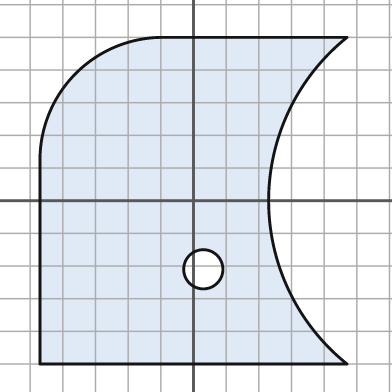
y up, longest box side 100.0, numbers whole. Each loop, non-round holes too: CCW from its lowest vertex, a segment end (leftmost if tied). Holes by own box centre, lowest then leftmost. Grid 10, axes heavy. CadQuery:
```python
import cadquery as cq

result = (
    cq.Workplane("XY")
    .moveTo(-47.0, -50.0)
    .lineTo(47.0, -50.0)
    .threePointArc((23.0, 0.0), (47.0, 50.0))
    .lineTo(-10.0, 50.0)
    .threePointArc((-36.0, 39.0), (-47.0, 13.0))
    .close()
    .moveTo(3.0, -21.0)
    .circle(6.0)
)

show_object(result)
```